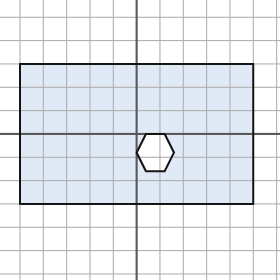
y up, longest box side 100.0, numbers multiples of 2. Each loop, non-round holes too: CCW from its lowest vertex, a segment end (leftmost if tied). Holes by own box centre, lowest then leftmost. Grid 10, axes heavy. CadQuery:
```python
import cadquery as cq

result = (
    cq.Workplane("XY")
    .moveTo(-50.0, -30.0)
    .lineTo(50.0, -30.0)
    .lineTo(50.0, 30.0)
    .lineTo(-50.0, 30.0)
    .close()
    .moveTo(4.0, -16.0)
    .lineTo(12.0, -16.0)
    .lineTo(16.0, -8.0)
    .lineTo(12.0, 0.0)
    .lineTo(4.0, 0.0)
    .lineTo(0.0, -8.0)
    .close()
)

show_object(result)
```